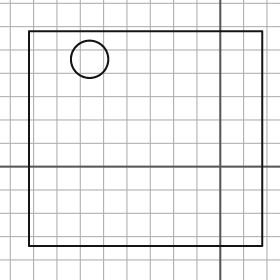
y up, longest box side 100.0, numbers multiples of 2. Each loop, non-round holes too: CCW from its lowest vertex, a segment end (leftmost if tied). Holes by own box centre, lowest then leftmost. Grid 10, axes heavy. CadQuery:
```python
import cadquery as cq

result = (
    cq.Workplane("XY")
    .moveTo(-82.0, -34.0)
    .lineTo(18.0, -34.0)
    .lineTo(18.0, 58.0)
    .lineTo(-82.0, 58.0)
    .close()
    .moveTo(-56.0, 46.0)
    .circle(8.0)
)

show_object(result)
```